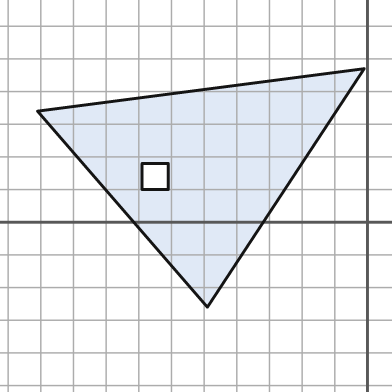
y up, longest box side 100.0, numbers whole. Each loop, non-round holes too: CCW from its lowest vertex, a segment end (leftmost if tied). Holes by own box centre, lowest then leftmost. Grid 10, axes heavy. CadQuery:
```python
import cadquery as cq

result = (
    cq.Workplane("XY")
    .moveTo(-49.0, -26.0)
    .lineTo(-1.0, 47.0)
    .lineTo(-101.0, 34.0)
    .close()
    .moveTo(-69.0, 10.0)
    .lineTo(-61.0, 10.0)
    .lineTo(-61.0, 18.0)
    .lineTo(-69.0, 18.0)
    .close()
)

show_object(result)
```